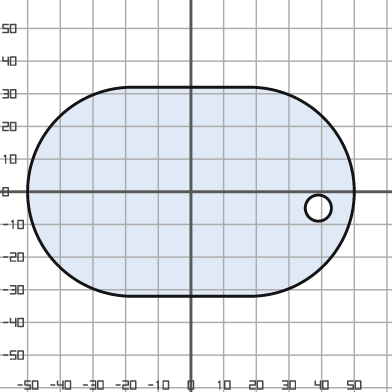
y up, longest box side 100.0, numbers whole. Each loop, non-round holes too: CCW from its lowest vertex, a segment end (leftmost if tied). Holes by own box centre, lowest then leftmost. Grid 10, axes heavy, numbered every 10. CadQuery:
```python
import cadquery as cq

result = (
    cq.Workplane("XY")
    .moveTo(-18.0, -32.0)
    .lineTo(18.0, -32.0)
    .threePointArc((50.0, 0.0), (18.0, 32.0))
    .lineTo(-18.0, 32.0)
    .threePointArc((-50.0, 0.0), (-18.0, -32.0))
    .close()
    .moveTo(39.0, -5.0)
    .circle(4.0)
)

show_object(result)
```